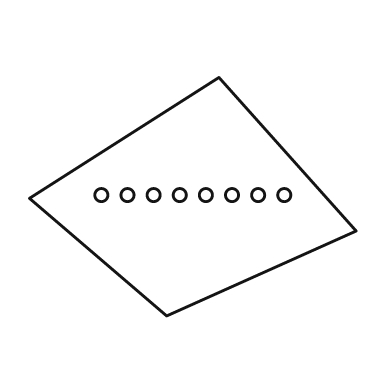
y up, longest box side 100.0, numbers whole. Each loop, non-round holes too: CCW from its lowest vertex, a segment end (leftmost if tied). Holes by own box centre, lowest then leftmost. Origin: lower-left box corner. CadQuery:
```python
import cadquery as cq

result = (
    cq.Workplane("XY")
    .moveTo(42.0, 0.0)
    .lineTo(100.0, 26.0)
    .lineTo(58.0, 73.0)
    .lineTo(0.0, 36.0)
    .close()
    .moveTo(22.0, 37.0)
    .circle(2.0)
    .moveTo(30.0, 37.0)
    .circle(2.0)
    .moveTo(38.0, 37.0)
    .circle(2.0)
    .moveTo(46.0, 37.0)
    .circle(2.0)
    .moveTo(54.0, 37.0)
    .circle(2.0)
    .moveTo(62.0, 37.0)
    .circle(2.0)
    .moveTo(70.0, 37.0)
    .circle(2.0)
    .moveTo(78.0, 37.0)
    .circle(2.0)
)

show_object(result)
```